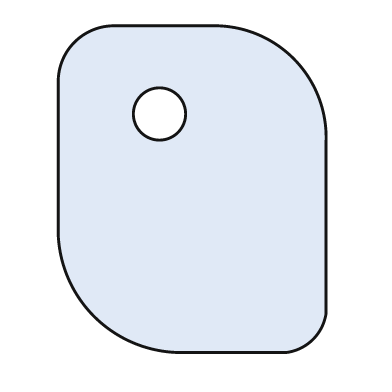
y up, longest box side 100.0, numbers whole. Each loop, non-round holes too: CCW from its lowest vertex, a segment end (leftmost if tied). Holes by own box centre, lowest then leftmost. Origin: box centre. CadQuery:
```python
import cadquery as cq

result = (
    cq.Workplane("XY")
    .moveTo(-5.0, -50.0)
    .lineTo(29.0, -50.0)
    .threePointArc((37.0, -46.0), (41.0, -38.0))
    .lineTo(41.0, 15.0)
    .threePointArc((31.0, 40.0), (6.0, 50.0))
    .lineTo(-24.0, 50.0)
    .threePointArc((-36.0, 45.0), (-41.0, 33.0))
    .lineTo(-41.0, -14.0)
    .threePointArc((-30.0, -39.0), (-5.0, -50.0))
    .close()
    .moveTo(-10.0, 23.0)
    .circle(8.0)
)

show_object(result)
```